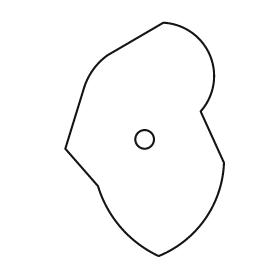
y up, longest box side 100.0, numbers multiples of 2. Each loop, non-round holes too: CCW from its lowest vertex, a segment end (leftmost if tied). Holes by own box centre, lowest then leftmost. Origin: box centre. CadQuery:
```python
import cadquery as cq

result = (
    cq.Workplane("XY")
    .moveTo(6.0, -50.0)
    .threePointArc((26.0, -34.0), (34.0, -10.0))
    .lineTo(24.0, 12.0)
    .threePointArc((28.0, 36.0), (8.0, 50.0))
    .lineTo(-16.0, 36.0)
    .threePointArc((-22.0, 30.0), (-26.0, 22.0))
    .lineTo(-34.0, -4.0)
    .lineTo(-20.0, -20.0)
    .threePointArc((-10.0, -38.0), (6.0, -50.0))
    .close()
    .moveTo(0.0, 0.0)
    .circle(4.0)
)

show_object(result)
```